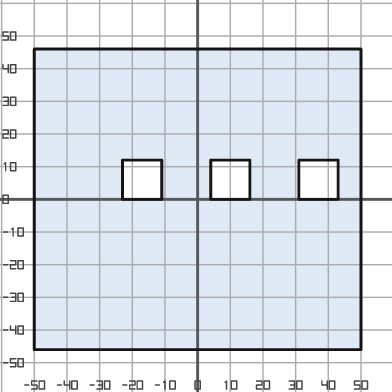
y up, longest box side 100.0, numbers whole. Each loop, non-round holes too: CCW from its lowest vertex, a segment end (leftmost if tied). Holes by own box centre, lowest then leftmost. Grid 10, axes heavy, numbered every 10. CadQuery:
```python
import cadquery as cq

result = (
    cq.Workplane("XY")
    .moveTo(-50.0, -46.0)
    .lineTo(50.0, -46.0)
    .lineTo(50.0, 46.0)
    .lineTo(-50.0, 46.0)
    .close()
    .moveTo(-23.0, 0.0)
    .lineTo(-11.0, 0.0)
    .lineTo(-11.0, 12.0)
    .lineTo(-23.0, 12.0)
    .close()
    .moveTo(4.0, 0.0)
    .lineTo(16.0, 0.0)
    .lineTo(16.0, 12.0)
    .lineTo(4.0, 12.0)
    .close()
    .moveTo(31.0, 0.0)
    .lineTo(43.0, 0.0)
    .lineTo(43.0, 12.0)
    .lineTo(31.0, 12.0)
    .close()
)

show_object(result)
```